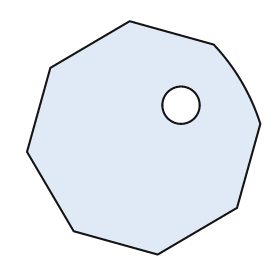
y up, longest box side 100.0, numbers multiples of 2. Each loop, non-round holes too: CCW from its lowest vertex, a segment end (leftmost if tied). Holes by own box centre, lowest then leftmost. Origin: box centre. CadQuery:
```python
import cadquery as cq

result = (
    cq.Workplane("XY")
    .moveTo(6.0, -50.0)
    .lineTo(40.0, -30.0)
    .lineTo(50.0, 6.0)
    .threePointArc((42.0, 24.0), (30.0, 40.0))
    .lineTo(-6.0, 50.0)
    .lineTo(-40.0, 30.0)
    .lineTo(-50.0, -6.0)
    .lineTo(-30.0, -40.0)
    .close()
    .moveTo(16.0, 14.0)
    .circle(8.0)
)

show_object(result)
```